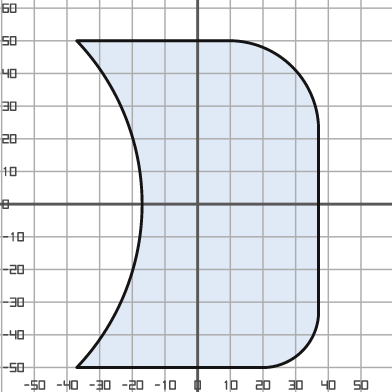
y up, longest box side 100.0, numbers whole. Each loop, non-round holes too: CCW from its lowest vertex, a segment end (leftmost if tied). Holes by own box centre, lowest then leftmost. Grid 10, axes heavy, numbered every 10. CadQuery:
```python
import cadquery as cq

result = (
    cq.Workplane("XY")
    .moveTo(-37.0, -50.0)
    .lineTo(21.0, -50.0)
    .threePointArc((32.0, -45.0), (37.0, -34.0))
    .lineTo(37.0, 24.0)
    .threePointArc((29.0, 42.0), (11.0, 50.0))
    .lineTo(-37.0, 50.0)
    .threePointArc((-17.0, 0.0), (-37.0, -50.0))
    .close()
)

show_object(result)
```